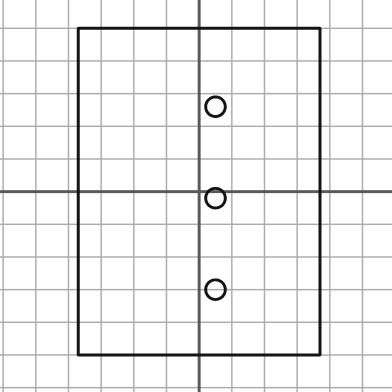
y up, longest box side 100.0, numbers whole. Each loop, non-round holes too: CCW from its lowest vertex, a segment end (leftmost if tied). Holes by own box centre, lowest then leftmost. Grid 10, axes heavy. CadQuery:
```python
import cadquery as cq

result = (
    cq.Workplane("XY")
    .moveTo(-37.0, -50.0)
    .lineTo(37.0, -50.0)
    .lineTo(37.0, 50.0)
    .lineTo(-37.0, 50.0)
    .close()
    .moveTo(5.0, -30.0)
    .circle(3.0)
    .moveTo(5.0, -2.0)
    .circle(3.0)
    .moveTo(5.0, 26.0)
    .circle(3.0)
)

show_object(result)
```